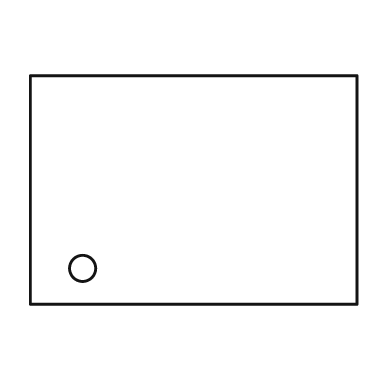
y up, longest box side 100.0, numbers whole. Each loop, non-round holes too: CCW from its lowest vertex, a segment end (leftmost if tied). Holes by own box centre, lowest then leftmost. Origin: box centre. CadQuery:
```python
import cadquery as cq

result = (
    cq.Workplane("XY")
    .moveTo(-50.0, -35.0)
    .lineTo(50.0, -35.0)
    .lineTo(50.0, 35.0)
    .lineTo(-50.0, 35.0)
    .close()
    .moveTo(-34.0, -24.0)
    .circle(4.0)
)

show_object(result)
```